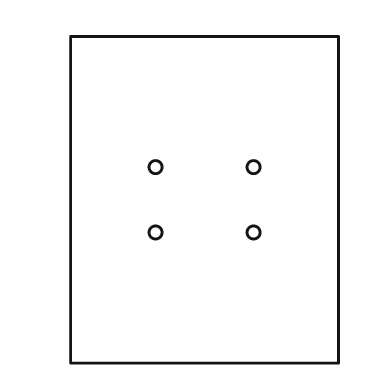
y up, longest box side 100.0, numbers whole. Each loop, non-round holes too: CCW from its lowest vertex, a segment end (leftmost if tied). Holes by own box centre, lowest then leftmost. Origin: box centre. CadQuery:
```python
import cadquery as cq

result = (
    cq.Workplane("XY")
    .moveTo(-41.0, -50.0)
    .lineTo(41.0, -50.0)
    .lineTo(41.0, 50.0)
    .lineTo(-41.0, 50.0)
    .close()
    .moveTo(-15.0, -10.0)
    .circle(2.0)
    .moveTo(15.0, -10.0)
    .circle(2.0)
    .moveTo(-15.0, 10.0)
    .circle(2.0)
    .moveTo(15.0, 10.0)
    .circle(2.0)
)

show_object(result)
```